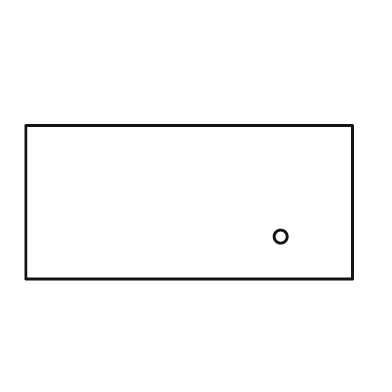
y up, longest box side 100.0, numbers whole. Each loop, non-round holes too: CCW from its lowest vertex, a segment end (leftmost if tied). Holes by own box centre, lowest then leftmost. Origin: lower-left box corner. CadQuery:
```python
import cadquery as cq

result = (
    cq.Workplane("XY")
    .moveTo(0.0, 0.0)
    .lineTo(100.0, 0.0)
    .lineTo(100.0, 47.0)
    .lineTo(0.0, 47.0)
    .close()
    .moveTo(78.0, 13.0)
    .circle(2.0)
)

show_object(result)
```